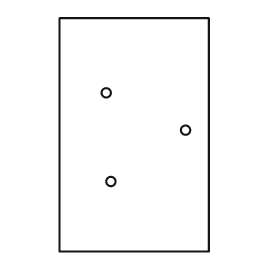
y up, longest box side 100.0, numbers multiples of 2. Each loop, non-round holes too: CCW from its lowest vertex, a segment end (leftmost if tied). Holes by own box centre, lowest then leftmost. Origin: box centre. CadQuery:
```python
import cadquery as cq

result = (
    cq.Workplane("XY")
    .moveTo(-32.0, -50.0)
    .lineTo(32.0, -50.0)
    .lineTo(32.0, 50.0)
    .lineTo(-32.0, 50.0)
    .close()
    .moveTo(-10.0, -20.0)
    .circle(2.0)
    .moveTo(22.0, 2.0)
    .circle(2.0)
    .moveTo(-12.0, 18.0)
    .circle(2.0)
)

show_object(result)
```